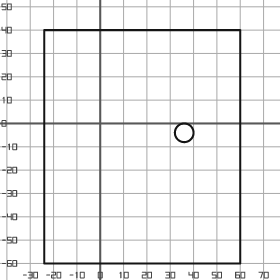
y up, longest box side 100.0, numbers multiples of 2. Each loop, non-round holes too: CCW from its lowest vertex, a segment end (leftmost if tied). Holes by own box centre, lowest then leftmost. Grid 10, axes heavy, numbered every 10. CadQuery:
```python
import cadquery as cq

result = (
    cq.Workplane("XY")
    .moveTo(-24.0, -60.0)
    .lineTo(60.0, -60.0)
    .lineTo(60.0, 40.0)
    .lineTo(-24.0, 40.0)
    .close()
    .moveTo(36.0, -4.0)
    .circle(4.0)
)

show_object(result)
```